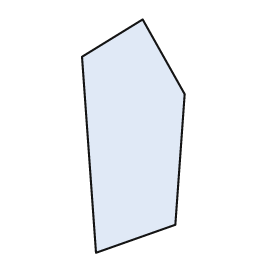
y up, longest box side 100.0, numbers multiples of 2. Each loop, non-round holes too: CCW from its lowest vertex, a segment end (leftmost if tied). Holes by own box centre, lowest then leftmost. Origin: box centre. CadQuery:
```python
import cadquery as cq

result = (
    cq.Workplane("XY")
    .moveTo(-16.0, -50.0)
    .lineTo(18.0, -38.0)
    .lineTo(22.0, 18.0)
    .lineTo(4.0, 50.0)
    .lineTo(-22.0, 34.0)
    .close()
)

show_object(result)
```